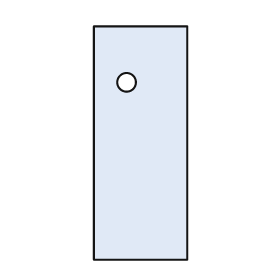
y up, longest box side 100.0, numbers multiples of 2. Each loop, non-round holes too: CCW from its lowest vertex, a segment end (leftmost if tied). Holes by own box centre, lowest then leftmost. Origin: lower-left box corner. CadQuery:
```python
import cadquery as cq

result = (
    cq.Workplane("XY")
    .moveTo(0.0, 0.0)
    .lineTo(40.0, 0.0)
    .lineTo(40.0, 100.0)
    .lineTo(0.0, 100.0)
    .close()
    .moveTo(14.0, 76.0)
    .circle(4.0)
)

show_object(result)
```